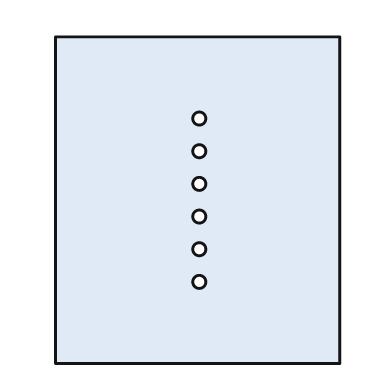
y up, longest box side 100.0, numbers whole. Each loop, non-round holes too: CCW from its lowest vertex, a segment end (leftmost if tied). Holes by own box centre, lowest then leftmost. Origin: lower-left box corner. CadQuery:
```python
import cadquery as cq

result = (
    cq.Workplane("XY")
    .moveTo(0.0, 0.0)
    .lineTo(87.0, 0.0)
    .lineTo(87.0, 100.0)
    .lineTo(0.0, 100.0)
    .close()
    .moveTo(44.0, 25.0)
    .circle(2.0)
    .moveTo(44.0, 35.0)
    .circle(2.0)
    .moveTo(44.0, 45.0)
    .circle(2.0)
    .moveTo(44.0, 55.0)
    .circle(2.0)
    .moveTo(44.0, 65.0)
    .circle(2.0)
    .moveTo(44.0, 75.0)
    .circle(2.0)
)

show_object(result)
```